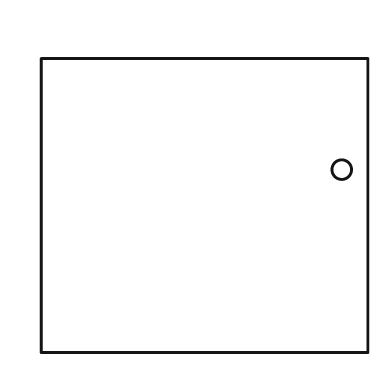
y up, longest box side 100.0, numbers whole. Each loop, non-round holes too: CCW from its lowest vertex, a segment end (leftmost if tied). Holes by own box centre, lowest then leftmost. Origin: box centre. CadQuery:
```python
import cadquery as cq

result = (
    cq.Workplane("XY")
    .moveTo(-50.0, -45.0)
    .lineTo(50.0, -45.0)
    .lineTo(50.0, 45.0)
    .lineTo(-50.0, 45.0)
    .close()
    .moveTo(42.0, 11.0)
    .circle(3.0)
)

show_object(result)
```